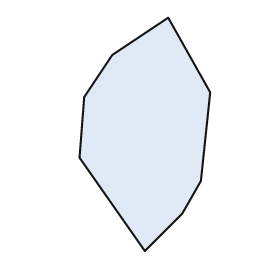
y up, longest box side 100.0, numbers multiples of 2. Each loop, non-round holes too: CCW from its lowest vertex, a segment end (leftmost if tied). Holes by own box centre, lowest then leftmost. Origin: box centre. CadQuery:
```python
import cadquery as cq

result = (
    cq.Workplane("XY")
    .moveTo(0.0, -50.0)
    .lineTo(16.0, -34.0)
    .lineTo(24.0, -20.0)
    .lineTo(28.0, 18.0)
    .lineTo(10.0, 50.0)
    .lineTo(-14.0, 34.0)
    .lineTo(-26.0, 16.0)
    .lineTo(-28.0, -10.0)
    .close()
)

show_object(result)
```